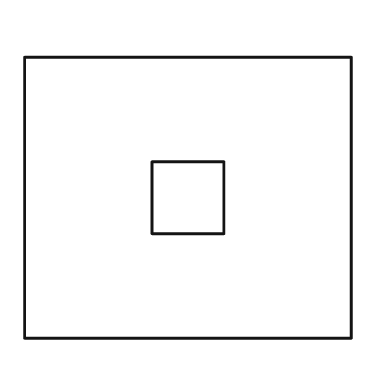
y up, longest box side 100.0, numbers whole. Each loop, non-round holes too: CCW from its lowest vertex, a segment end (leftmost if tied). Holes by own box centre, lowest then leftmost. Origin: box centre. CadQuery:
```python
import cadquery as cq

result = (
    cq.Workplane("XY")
    .moveTo(-50.0, -43.0)
    .lineTo(50.0, -43.0)
    .lineTo(50.0, 43.0)
    .lineTo(-50.0, 43.0)
    .close()
    .moveTo(-11.0, -11.0)
    .lineTo(11.0, -11.0)
    .lineTo(11.0, 11.0)
    .lineTo(-11.0, 11.0)
    .close()
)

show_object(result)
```